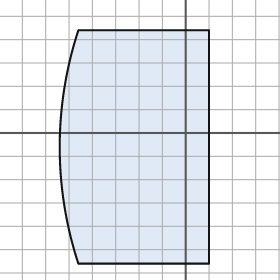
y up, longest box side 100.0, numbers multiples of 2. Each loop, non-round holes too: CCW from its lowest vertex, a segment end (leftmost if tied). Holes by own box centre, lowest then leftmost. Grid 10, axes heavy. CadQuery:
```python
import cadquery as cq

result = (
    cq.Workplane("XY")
    .moveTo(-46.0, -56.0)
    .lineTo(10.0, -56.0)
    .lineTo(10.0, 44.0)
    .lineTo(-46.0, 44.0)
    .threePointArc((-54.0, -6.0), (-46.0, -56.0))
    .close()
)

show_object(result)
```